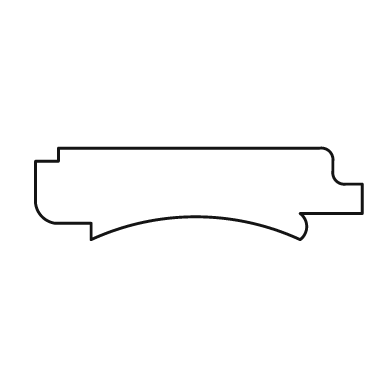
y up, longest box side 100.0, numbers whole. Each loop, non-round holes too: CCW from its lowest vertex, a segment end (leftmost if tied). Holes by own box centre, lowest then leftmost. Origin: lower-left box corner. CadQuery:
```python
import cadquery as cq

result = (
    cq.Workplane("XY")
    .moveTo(17.0, 0.0)
    .threePointArc((49.0, 7.0), (81.0, 0.0))
    .threePointArc((83.0, 4.0), (81.0, 8.0))
    .lineTo(100.0, 8.0)
    .lineTo(100.0, 17.0)
    .lineTo(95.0, 17.0)
    .threePointArc((92.0, 18.0), (91.0, 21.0))
    .lineTo(91.0, 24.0)
    .threePointArc((90.0, 27.0), (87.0, 28.0))
    .lineTo(7.0, 28.0)
    .lineTo(7.0, 24.0)
    .lineTo(0.0, 24.0)
    .lineTo(0.0, 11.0)
    .threePointArc((2.0, 7.0), (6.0, 5.0))
    .lineTo(17.0, 5.0)
    .close()
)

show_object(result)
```